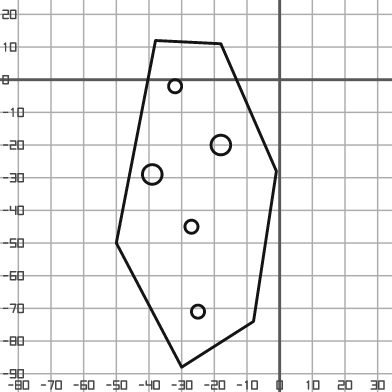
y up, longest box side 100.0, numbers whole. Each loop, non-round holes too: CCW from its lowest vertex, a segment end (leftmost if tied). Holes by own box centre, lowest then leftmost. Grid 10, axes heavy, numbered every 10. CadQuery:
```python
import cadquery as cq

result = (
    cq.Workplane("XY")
    .moveTo(-30.0, -88.0)
    .lineTo(-8.0, -74.0)
    .lineTo(-1.0, -28.0)
    .lineTo(-18.0, 11.0)
    .lineTo(-38.0, 12.0)
    .lineTo(-50.0, -50.0)
    .close()
    .moveTo(-25.0, -71.0)
    .circle(2.0)
    .moveTo(-27.0, -45.0)
    .circle(2.0)
    .moveTo(-39.0, -29.0)
    .circle(3.0)
    .moveTo(-18.0, -20.0)
    .circle(3.0)
    .moveTo(-32.0, -2.0)
    .circle(2.0)
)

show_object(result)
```